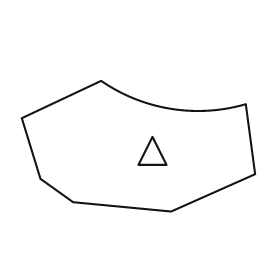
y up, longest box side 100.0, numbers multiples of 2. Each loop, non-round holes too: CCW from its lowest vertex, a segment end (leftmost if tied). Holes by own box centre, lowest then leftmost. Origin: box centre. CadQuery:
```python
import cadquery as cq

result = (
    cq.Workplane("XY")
    .moveTo(14.0, -28.0)
    .lineTo(50.0, -12.0)
    .lineTo(46.0, 18.0)
    .threePointArc((14.0, 16.0), (-16.0, 28.0))
    .lineTo(-50.0, 12.0)
    .lineTo(-42.0, -14.0)
    .lineTo(-28.0, -24.0)
    .close()
    .moveTo(0.0, -8.0)
    .lineTo(12.0, -8.0)
    .lineTo(6.0, 4.0)
    .close()
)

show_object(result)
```